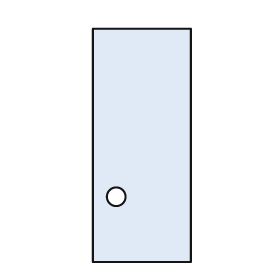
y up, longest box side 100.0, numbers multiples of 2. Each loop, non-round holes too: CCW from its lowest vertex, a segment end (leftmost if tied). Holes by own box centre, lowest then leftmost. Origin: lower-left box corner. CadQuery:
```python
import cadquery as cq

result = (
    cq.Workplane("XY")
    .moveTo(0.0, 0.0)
    .lineTo(42.0, 0.0)
    .lineTo(42.0, 100.0)
    .lineTo(0.0, 100.0)
    .close()
    .moveTo(10.0, 28.0)
    .circle(4.0)
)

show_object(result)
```